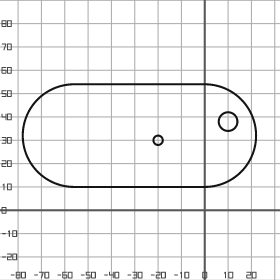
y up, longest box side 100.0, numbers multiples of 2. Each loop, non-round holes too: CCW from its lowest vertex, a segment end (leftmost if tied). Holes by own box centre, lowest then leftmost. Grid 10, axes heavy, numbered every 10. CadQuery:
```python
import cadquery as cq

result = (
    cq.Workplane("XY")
    .moveTo(-56.0, 10.0)
    .lineTo(0.0, 10.0)
    .threePointArc((22.0, 32.0), (0.0, 54.0))
    .lineTo(-56.0, 54.0)
    .threePointArc((-78.0, 32.0), (-56.0, 10.0))
    .close()
    .moveTo(-20.0, 30.0)
    .circle(2.0)
    .moveTo(10.0, 38.0)
    .circle(4.0)
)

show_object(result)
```